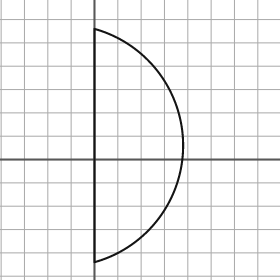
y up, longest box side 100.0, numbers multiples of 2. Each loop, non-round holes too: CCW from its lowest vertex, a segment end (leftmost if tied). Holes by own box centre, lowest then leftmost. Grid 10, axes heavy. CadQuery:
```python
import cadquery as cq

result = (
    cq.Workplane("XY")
    .moveTo(0.0, -44.0)
    .threePointArc((38.0, 6.0), (0.0, 56.0))
    .close()
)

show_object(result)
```